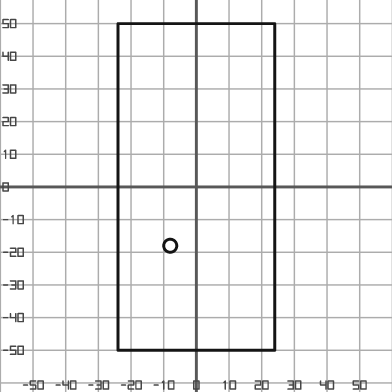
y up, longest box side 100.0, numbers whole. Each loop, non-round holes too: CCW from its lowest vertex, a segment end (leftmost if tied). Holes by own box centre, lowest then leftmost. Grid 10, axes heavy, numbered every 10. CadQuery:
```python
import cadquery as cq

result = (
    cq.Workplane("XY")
    .moveTo(-24.0, -50.0)
    .lineTo(24.0, -50.0)
    .lineTo(24.0, 50.0)
    .lineTo(-24.0, 50.0)
    .close()
    .moveTo(-8.0, -18.0)
    .circle(2.0)
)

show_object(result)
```